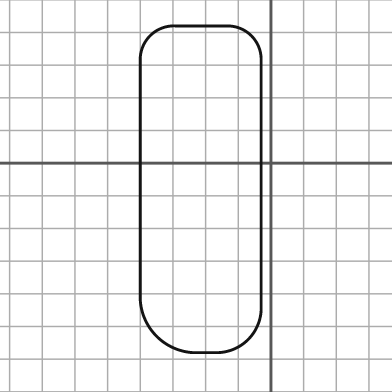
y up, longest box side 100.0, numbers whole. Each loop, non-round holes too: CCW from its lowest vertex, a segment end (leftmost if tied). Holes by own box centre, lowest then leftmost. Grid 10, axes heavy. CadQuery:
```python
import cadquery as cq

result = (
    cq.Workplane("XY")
    .moveTo(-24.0, -58.0)
    .lineTo(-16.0, -58.0)
    .threePointArc((-7.0, -54.0), (-3.0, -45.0))
    .lineTo(-3.0, 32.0)
    .threePointArc((-6.0, 39.0), (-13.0, 42.0))
    .lineTo(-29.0, 42.0)
    .threePointArc((-37.0, 39.0), (-40.0, 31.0))
    .lineTo(-40.0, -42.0)
    .threePointArc((-35.0, -53.0), (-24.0, -58.0))
    .close()
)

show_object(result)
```